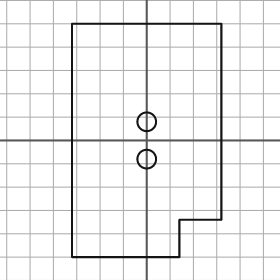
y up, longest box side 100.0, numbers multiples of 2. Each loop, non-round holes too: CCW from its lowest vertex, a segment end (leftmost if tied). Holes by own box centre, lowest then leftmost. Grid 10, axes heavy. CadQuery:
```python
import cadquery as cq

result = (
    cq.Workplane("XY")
    .moveTo(-32.0, -50.0)
    .lineTo(14.0, -50.0)
    .lineTo(14.0, -34.0)
    .lineTo(32.0, -34.0)
    .lineTo(32.0, 50.0)
    .lineTo(-32.0, 50.0)
    .close()
    .moveTo(0.0, -8.0)
    .circle(4.0)
    .moveTo(0.0, 8.0)
    .circle(4.0)
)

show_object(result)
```